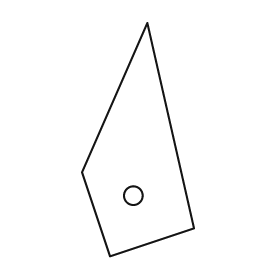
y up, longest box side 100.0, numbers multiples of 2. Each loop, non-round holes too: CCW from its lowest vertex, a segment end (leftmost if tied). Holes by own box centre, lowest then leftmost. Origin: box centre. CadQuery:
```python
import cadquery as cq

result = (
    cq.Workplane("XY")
    .moveTo(-12.0, -50.0)
    .lineTo(24.0, -38.0)
    .lineTo(4.0, 50.0)
    .lineTo(-24.0, -14.0)
    .close()
    .moveTo(-2.0, -24.0)
    .circle(4.0)
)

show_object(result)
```